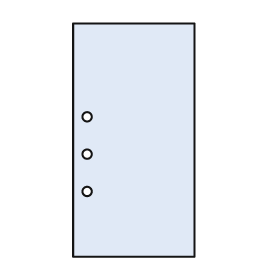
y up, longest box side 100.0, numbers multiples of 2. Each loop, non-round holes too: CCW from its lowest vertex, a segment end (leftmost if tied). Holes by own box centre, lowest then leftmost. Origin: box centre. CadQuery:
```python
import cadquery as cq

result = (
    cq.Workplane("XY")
    .moveTo(-26.0, -50.0)
    .lineTo(26.0, -50.0)
    .lineTo(26.0, 50.0)
    .lineTo(-26.0, 50.0)
    .close()
    .moveTo(-20.0, -22.0)
    .circle(2.0)
    .moveTo(-20.0, -6.0)
    .circle(2.0)
    .moveTo(-20.0, 10.0)
    .circle(2.0)
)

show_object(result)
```